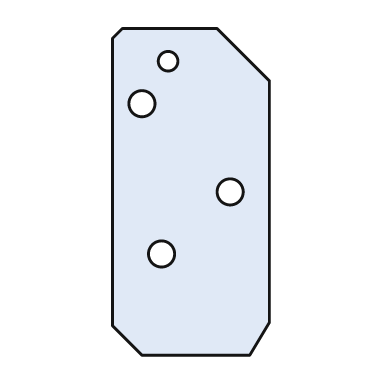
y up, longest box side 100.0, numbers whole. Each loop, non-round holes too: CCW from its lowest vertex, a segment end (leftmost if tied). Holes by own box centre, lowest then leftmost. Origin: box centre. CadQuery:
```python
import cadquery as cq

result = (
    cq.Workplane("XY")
    .moveTo(-15.0, -50.0)
    .lineTo(18.0, -50.0)
    .lineTo(24.0, -40.0)
    .lineTo(24.0, 34.0)
    .lineTo(8.0, 50.0)
    .lineTo(-21.0, 50.0)
    .lineTo(-24.0, 47.0)
    .lineTo(-24.0, -41.0)
    .close()
    .moveTo(-9.0, -19.0)
    .circle(4.0)
    .moveTo(12.0, 0.0)
    .circle(4.0)
    .moveTo(-15.0, 27.0)
    .circle(4.0)
    .moveTo(-7.0, 40.0)
    .circle(3.0)
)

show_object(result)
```